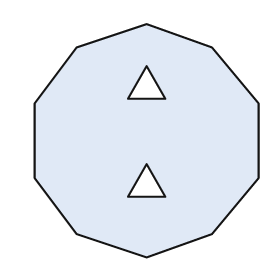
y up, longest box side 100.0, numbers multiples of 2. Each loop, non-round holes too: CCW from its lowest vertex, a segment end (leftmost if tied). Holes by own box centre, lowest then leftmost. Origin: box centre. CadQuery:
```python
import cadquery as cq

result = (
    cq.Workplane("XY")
    .moveTo(0.0, -50.0)
    .lineTo(28.0, -40.0)
    .lineTo(48.0, -16.0)
    .lineTo(48.0, 16.0)
    .lineTo(28.0, 40.0)
    .lineTo(0.0, 50.0)
    .lineTo(-30.0, 40.0)
    .lineTo(-48.0, 16.0)
    .lineTo(-48.0, -16.0)
    .lineTo(-30.0, -40.0)
    .close()
    .moveTo(-8.0, -24.0)
    .lineTo(8.0, -24.0)
    .lineTo(0.0, -10.0)
    .close()
    .moveTo(-8.0, 18.0)
    .lineTo(8.0, 18.0)
    .lineTo(0.0, 32.0)
    .close()
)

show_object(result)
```